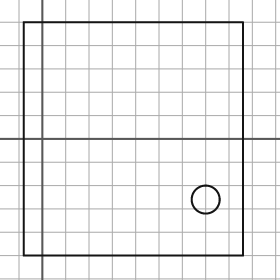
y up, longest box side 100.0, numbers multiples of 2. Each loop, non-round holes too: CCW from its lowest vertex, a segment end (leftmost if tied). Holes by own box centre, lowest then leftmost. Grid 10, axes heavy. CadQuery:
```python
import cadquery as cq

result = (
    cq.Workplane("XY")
    .moveTo(-8.0, -50.0)
    .lineTo(86.0, -50.0)
    .lineTo(86.0, 50.0)
    .lineTo(-8.0, 50.0)
    .close()
    .moveTo(70.0, -26.0)
    .circle(6.0)
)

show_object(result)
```